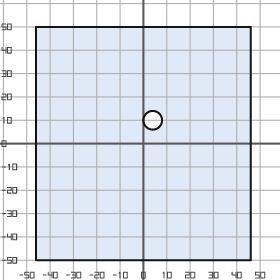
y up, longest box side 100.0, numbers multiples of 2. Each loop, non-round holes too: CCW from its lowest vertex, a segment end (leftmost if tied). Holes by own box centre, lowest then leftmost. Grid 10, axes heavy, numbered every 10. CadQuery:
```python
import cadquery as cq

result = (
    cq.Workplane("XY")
    .moveTo(-46.0, -50.0)
    .lineTo(46.0, -50.0)
    .lineTo(46.0, 50.0)
    .lineTo(-46.0, 50.0)
    .close()
    .moveTo(4.0, 10.0)
    .circle(4.0)
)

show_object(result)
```